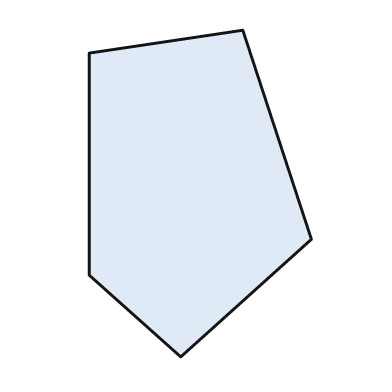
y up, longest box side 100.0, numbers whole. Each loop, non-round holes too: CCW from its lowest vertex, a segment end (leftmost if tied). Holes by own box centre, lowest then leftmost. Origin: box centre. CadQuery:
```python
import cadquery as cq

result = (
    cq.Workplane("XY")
    .moveTo(-6.0, -50.0)
    .lineTo(34.0, -14.0)
    .lineTo(13.0, 50.0)
    .lineTo(-34.0, 43.0)
    .lineTo(-34.0, -25.0)
    .close()
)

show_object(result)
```